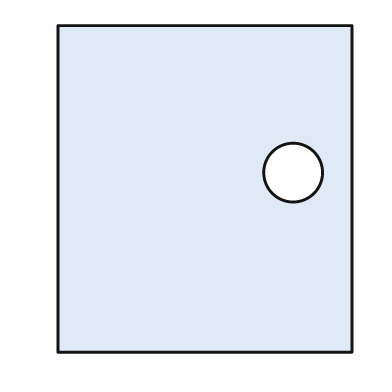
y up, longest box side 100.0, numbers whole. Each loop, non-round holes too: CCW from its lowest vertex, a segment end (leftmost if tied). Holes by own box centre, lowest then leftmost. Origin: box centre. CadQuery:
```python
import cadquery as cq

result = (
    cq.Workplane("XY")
    .moveTo(-45.0, -50.0)
    .lineTo(45.0, -50.0)
    .lineTo(45.0, 50.0)
    .lineTo(-45.0, 50.0)
    .close()
    .moveTo(27.0, 5.0)
    .circle(9.0)
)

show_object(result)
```